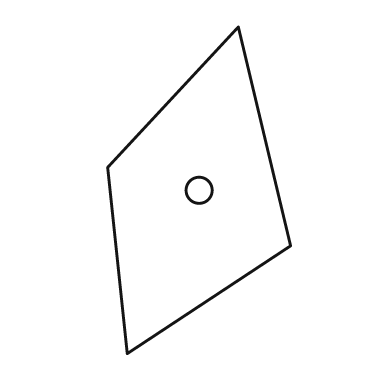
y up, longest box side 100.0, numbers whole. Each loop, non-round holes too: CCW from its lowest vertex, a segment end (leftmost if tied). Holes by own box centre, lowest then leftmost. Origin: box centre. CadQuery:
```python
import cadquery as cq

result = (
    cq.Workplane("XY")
    .moveTo(-22.0, -50.0)
    .lineTo(28.0, -17.0)
    .lineTo(12.0, 50.0)
    .lineTo(-28.0, 7.0)
    .close()
    .moveTo(0.0, 0.0)
    .circle(4.0)
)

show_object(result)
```